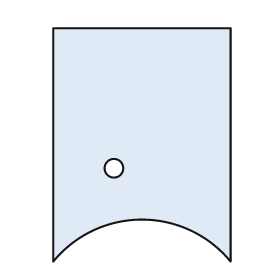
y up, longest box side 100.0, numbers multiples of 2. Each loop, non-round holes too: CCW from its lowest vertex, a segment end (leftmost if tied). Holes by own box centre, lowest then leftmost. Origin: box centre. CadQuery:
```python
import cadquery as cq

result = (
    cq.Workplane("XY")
    .moveTo(-38.0, -50.0)
    .threePointArc((0.0, -32.0), (38.0, -50.0))
    .lineTo(38.0, 50.0)
    .lineTo(-38.0, 50.0)
    .close()
    .moveTo(-12.0, -10.0)
    .circle(4.0)
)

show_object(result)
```